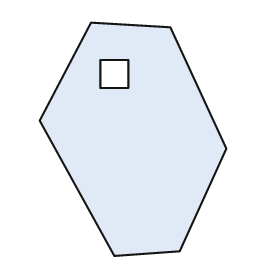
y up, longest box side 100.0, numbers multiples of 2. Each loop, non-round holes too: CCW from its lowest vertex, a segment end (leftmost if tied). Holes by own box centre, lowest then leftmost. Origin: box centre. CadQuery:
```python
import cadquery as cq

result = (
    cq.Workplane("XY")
    .moveTo(-8.0, -50.0)
    .lineTo(20.0, -48.0)
    .lineTo(40.0, -4.0)
    .lineTo(16.0, 48.0)
    .lineTo(-18.0, 50.0)
    .lineTo(-40.0, 8.0)
    .close()
    .moveTo(-14.0, 22.0)
    .lineTo(-2.0, 22.0)
    .lineTo(-2.0, 34.0)
    .lineTo(-14.0, 34.0)
    .close()
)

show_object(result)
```